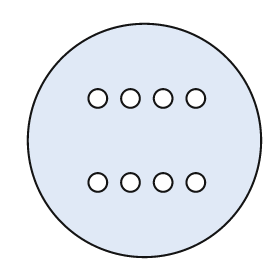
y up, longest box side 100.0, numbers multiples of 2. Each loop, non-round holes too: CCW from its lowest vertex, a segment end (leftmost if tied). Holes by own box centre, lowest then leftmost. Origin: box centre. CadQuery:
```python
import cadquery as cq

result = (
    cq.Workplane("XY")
    .moveTo(0.0, 0.0)
    .circle(50.0)
    .moveTo(-20.0, -18.0)
    .circle(4.0)
    .moveTo(-6.0, -18.0)
    .circle(4.0)
    .moveTo(8.0, -18.0)
    .circle(4.0)
    .moveTo(22.0, -18.0)
    .circle(4.0)
    .moveTo(-20.0, 18.0)
    .circle(4.0)
    .moveTo(-6.0, 18.0)
    .circle(4.0)
    .moveTo(8.0, 18.0)
    .circle(4.0)
    .moveTo(22.0, 18.0)
    .circle(4.0)
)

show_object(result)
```